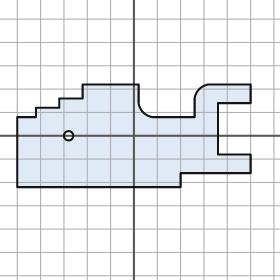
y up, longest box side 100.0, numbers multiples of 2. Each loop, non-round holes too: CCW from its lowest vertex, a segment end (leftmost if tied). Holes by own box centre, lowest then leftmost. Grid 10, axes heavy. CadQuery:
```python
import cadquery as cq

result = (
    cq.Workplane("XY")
    .moveTo(-50.0, -22.0)
    .lineTo(20.0, -22.0)
    .lineTo(20.0, -16.0)
    .lineTo(50.0, -16.0)
    .lineTo(50.0, -8.0)
    .lineTo(36.0, -8.0)
    .lineTo(36.0, 14.0)
    .lineTo(50.0, 14.0)
    .lineTo(50.0, 22.0)
    .lineTo(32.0, 22.0)
    .threePointArc((28.0, 20.0), (26.0, 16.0))
    .lineTo(26.0, 8.0)
    .lineTo(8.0, 8.0)
    .threePointArc((4.0, 10.0), (2.0, 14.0))
    .lineTo(2.0, 22.0)
    .lineTo(-22.0, 22.0)
    .lineTo(-22.0, 16.0)
    .lineTo(-32.0, 16.0)
    .lineTo(-32.0, 12.0)
    .lineTo(-42.0, 12.0)
    .lineTo(-42.0, 8.0)
    .lineTo(-50.0, 8.0)
    .close()
    .moveTo(-28.0, 0.0)
    .circle(2.0)
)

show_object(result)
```